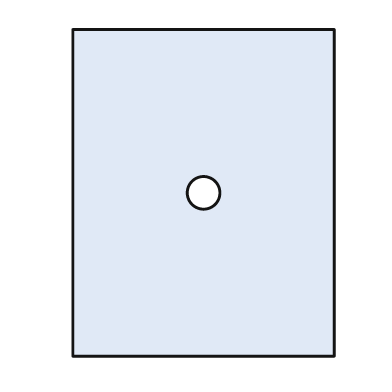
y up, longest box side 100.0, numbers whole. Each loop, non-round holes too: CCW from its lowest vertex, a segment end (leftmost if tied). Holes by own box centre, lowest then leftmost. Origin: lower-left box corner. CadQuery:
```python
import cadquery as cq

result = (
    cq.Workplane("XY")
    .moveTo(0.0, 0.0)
    .lineTo(80.0, 0.0)
    .lineTo(80.0, 100.0)
    .lineTo(0.0, 100.0)
    .close()
    .moveTo(40.0, 50.0)
    .circle(5.0)
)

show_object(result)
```